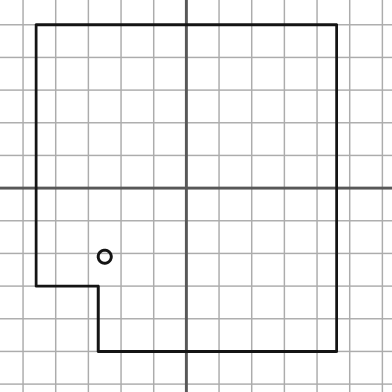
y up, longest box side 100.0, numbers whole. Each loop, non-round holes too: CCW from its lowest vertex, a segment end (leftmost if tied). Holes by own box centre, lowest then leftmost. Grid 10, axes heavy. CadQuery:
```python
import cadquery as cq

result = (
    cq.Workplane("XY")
    .moveTo(-27.0, -50.0)
    .lineTo(46.0, -50.0)
    .lineTo(46.0, 50.0)
    .lineTo(-46.0, 50.0)
    .lineTo(-46.0, -30.0)
    .lineTo(-27.0, -30.0)
    .close()
    .moveTo(-25.0, -21.0)
    .circle(2.0)
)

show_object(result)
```